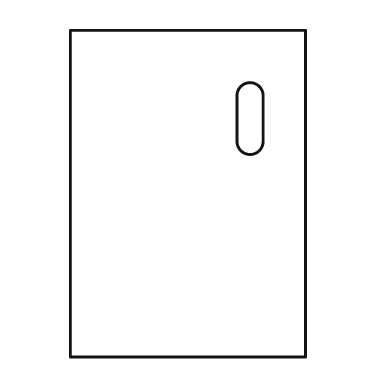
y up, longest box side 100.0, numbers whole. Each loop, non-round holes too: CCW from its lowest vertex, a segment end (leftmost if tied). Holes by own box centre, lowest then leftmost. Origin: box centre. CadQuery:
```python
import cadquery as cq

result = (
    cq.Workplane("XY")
    .moveTo(-36.0, -50.0)
    .lineTo(36.0, -50.0)
    .lineTo(36.0, 50.0)
    .lineTo(-36.0, 50.0)
    .close()
    .moveTo(15.0, 16.0)
    .threePointArc((19.0, 12.0), (23.0, 16.0))
    .lineTo(23.0, 30.0)
    .threePointArc((19.0, 34.0), (15.0, 30.0))
    .close()
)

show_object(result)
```